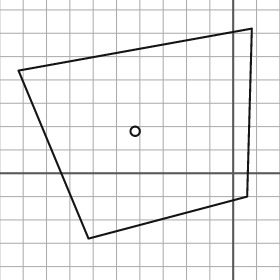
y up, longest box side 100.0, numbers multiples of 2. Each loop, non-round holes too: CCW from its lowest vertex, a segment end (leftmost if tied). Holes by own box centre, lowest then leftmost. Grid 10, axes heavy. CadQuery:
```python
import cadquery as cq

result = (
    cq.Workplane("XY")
    .moveTo(-62.0, -28.0)
    .lineTo(6.0, -10.0)
    .lineTo(8.0, 62.0)
    .lineTo(-92.0, 44.0)
    .close()
    .moveTo(-42.0, 18.0)
    .circle(2.0)
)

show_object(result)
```